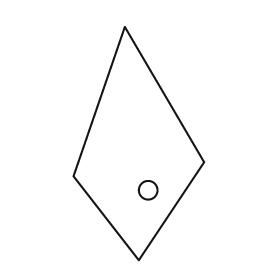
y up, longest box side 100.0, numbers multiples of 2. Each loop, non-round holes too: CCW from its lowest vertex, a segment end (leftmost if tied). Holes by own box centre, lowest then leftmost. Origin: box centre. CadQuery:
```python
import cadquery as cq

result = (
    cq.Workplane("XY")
    .moveTo(0.0, -50.0)
    .lineTo(28.0, -8.0)
    .lineTo(-6.0, 50.0)
    .lineTo(-28.0, -14.0)
    .close()
    .moveTo(4.0, -20.0)
    .circle(4.0)
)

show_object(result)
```